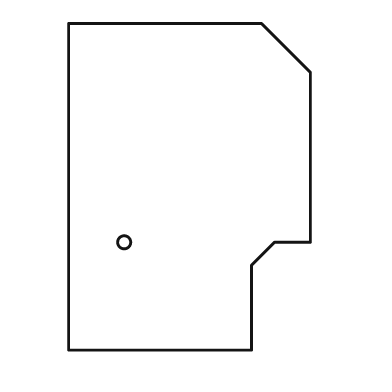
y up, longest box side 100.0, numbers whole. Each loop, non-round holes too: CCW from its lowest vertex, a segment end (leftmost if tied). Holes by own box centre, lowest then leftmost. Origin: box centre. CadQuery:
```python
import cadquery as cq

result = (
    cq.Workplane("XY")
    .moveTo(-37.0, -50.0)
    .lineTo(19.0, -50.0)
    .lineTo(19.0, -24.0)
    .lineTo(26.0, -17.0)
    .lineTo(37.0, -17.0)
    .lineTo(37.0, 35.0)
    .lineTo(22.0, 50.0)
    .lineTo(-37.0, 50.0)
    .close()
    .moveTo(-20.0, -17.0)
    .circle(2.0)
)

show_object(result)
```